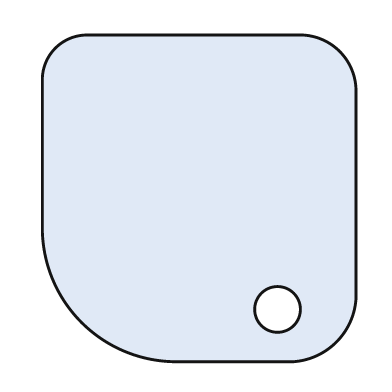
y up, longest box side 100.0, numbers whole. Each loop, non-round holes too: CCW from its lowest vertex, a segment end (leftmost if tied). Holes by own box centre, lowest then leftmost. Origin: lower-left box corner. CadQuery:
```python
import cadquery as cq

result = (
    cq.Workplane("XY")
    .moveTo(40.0, 0.0)
    .lineTo(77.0, 0.0)
    .threePointArc((90.0, 6.0), (96.0, 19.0))
    .lineTo(96.0, 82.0)
    .threePointArc((91.0, 95.0), (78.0, 100.0))
    .lineTo(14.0, 100.0)
    .threePointArc((4.0, 96.0), (0.0, 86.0))
    .lineTo(0.0, 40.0)
    .threePointArc((12.0, 12.0), (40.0, 0.0))
    .close()
    .moveTo(72.0, 16.0)
    .circle(7.0)
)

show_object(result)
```